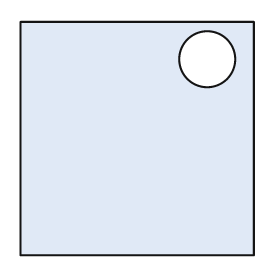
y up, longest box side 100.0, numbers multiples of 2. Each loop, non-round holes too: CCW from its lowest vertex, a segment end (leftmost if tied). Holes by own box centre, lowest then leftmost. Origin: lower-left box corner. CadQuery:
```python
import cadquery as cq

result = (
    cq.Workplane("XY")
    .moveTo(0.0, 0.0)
    .lineTo(100.0, 0.0)
    .lineTo(100.0, 100.0)
    .lineTo(0.0, 100.0)
    .close()
    .moveTo(80.0, 84.0)
    .circle(12.0)
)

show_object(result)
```